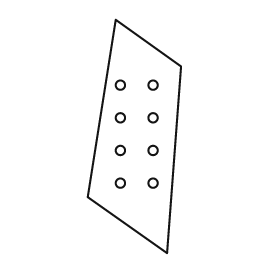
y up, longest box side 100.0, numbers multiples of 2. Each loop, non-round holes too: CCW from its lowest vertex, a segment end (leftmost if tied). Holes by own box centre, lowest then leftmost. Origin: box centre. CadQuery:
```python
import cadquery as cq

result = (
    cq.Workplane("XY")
    .moveTo(14.0, -50.0)
    .lineTo(20.0, 30.0)
    .lineTo(-8.0, 50.0)
    .lineTo(-20.0, -26.0)
    .close()
    .moveTo(-6.0, -20.0)
    .circle(2.0)
    .moveTo(8.0, -20.0)
    .circle(2.0)
    .moveTo(-6.0, -6.0)
    .circle(2.0)
    .moveTo(8.0, -6.0)
    .circle(2.0)
    .moveTo(-6.0, 8.0)
    .circle(2.0)
    .moveTo(8.0, 8.0)
    .circle(2.0)
    .moveTo(-6.0, 22.0)
    .circle(2.0)
    .moveTo(8.0, 22.0)
    .circle(2.0)
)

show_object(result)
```